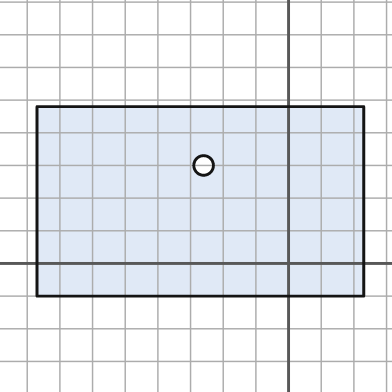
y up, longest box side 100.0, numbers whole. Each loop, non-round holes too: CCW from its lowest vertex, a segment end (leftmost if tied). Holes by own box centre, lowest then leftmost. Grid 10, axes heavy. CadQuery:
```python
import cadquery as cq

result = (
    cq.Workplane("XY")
    .moveTo(-77.0, -10.0)
    .lineTo(23.0, -10.0)
    .lineTo(23.0, 48.0)
    .lineTo(-77.0, 48.0)
    .close()
    .moveTo(-26.0, 30.0)
    .circle(3.0)
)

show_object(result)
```